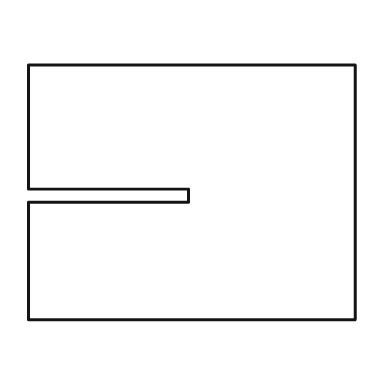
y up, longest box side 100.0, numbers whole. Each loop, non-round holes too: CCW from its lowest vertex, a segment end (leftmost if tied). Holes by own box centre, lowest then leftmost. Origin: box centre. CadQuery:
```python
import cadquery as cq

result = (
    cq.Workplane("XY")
    .moveTo(-50.0, -39.0)
    .lineTo(50.0, -39.0)
    .lineTo(50.0, 39.0)
    .lineTo(-50.0, 39.0)
    .lineTo(-50.0, 1.0)
    .lineTo(-1.0, 1.0)
    .lineTo(-1.0, -3.0)
    .lineTo(-50.0, -3.0)
    .close()
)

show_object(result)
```